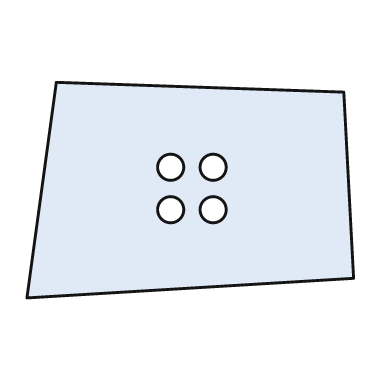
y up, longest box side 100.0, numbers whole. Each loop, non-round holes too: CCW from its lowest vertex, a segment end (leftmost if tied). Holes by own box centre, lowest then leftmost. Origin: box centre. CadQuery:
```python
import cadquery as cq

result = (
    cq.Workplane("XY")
    .moveTo(-50.0, -33.0)
    .lineTo(50.0, -27.0)
    .lineTo(47.0, 30.0)
    .lineTo(-41.0, 33.0)
    .close()
    .moveTo(-6.0, -6.0)
    .circle(4.0)
    .moveTo(7.0, -6.0)
    .circle(4.0)
    .moveTo(-6.0, 7.0)
    .circle(4.0)
    .moveTo(7.0, 7.0)
    .circle(4.0)
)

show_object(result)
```